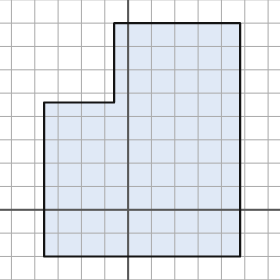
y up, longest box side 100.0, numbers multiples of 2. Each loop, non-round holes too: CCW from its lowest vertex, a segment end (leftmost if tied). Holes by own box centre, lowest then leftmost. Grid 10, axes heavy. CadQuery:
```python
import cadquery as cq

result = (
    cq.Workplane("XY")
    .moveTo(-36.0, -20.0)
    .lineTo(48.0, -20.0)
    .lineTo(48.0, 80.0)
    .lineTo(-6.0, 80.0)
    .lineTo(-6.0, 46.0)
    .lineTo(-36.0, 46.0)
    .close()
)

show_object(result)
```